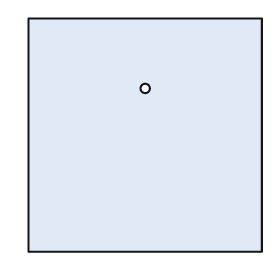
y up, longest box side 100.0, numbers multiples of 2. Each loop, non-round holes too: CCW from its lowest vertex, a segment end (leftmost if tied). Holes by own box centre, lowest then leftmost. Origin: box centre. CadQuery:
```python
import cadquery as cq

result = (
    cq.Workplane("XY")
    .moveTo(-50.0, -50.0)
    .lineTo(50.0, -50.0)
    .lineTo(50.0, 50.0)
    .lineTo(-50.0, 50.0)
    .close()
    .moveTo(0.0, 20.0)
    .circle(2.0)
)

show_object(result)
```